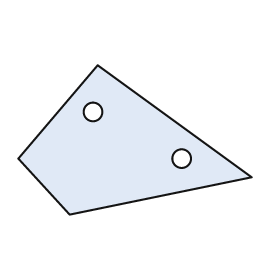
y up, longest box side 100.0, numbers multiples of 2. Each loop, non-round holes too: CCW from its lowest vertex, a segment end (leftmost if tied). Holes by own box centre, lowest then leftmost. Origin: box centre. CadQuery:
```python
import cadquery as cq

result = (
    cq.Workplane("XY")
    .moveTo(-28.0, -32.0)
    .lineTo(50.0, -16.0)
    .lineTo(-16.0, 32.0)
    .lineTo(-50.0, -8.0)
    .close()
    .moveTo(20.0, -8.0)
    .circle(4.0)
    .moveTo(-18.0, 12.0)
    .circle(4.0)
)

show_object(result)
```